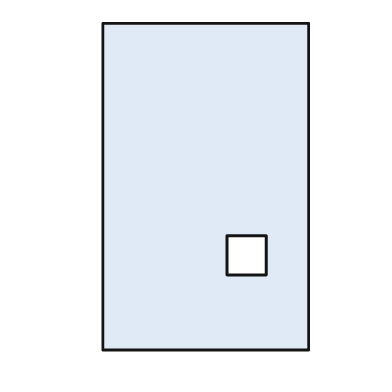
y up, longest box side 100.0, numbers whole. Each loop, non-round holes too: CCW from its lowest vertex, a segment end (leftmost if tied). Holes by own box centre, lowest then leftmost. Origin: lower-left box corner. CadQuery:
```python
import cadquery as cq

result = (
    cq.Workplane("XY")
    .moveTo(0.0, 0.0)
    .lineTo(63.0, 0.0)
    .lineTo(63.0, 100.0)
    .lineTo(0.0, 100.0)
    .close()
    .moveTo(38.0, 23.0)
    .lineTo(50.0, 23.0)
    .lineTo(50.0, 35.0)
    .lineTo(38.0, 35.0)
    .close()
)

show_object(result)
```